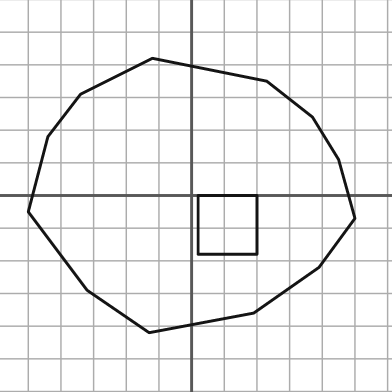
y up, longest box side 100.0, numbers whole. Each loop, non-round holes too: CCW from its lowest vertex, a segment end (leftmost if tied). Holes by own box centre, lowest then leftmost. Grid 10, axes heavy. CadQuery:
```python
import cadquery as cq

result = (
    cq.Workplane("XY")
    .moveTo(-13.0, -42.0)
    .lineTo(19.0, -36.0)
    .lineTo(39.0, -22.0)
    .lineTo(50.0, -7.0)
    .lineTo(45.0, 11.0)
    .lineTo(37.0, 24.0)
    .lineTo(23.0, 35.0)
    .lineTo(-12.0, 42.0)
    .lineTo(-34.0, 31.0)
    .lineTo(-44.0, 18.0)
    .lineTo(-50.0, -5.0)
    .lineTo(-32.0, -29.0)
    .close()
    .moveTo(2.0, -18.0)
    .lineTo(20.0, -18.0)
    .lineTo(20.0, 0.0)
    .lineTo(2.0, 0.0)
    .close()
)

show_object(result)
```